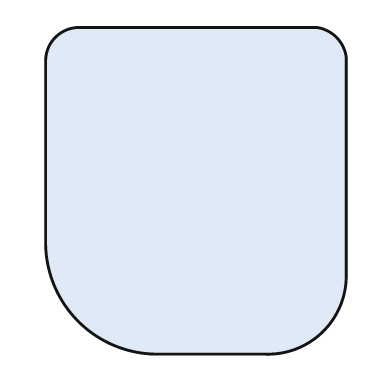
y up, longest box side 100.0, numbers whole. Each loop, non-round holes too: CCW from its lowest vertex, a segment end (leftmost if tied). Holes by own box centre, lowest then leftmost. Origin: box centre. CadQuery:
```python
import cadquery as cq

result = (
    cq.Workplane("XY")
    .moveTo(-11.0, -50.0)
    .lineTo(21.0, -50.0)
    .threePointArc((39.0, -43.0), (46.0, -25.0))
    .lineTo(46.0, 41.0)
    .threePointArc((43.0, 47.0), (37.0, 50.0))
    .lineTo(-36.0, 50.0)
    .threePointArc((-43.0, 47.0), (-46.0, 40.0))
    .lineTo(-46.0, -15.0)
    .threePointArc((-36.0, -40.0), (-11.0, -50.0))
    .close()
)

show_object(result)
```